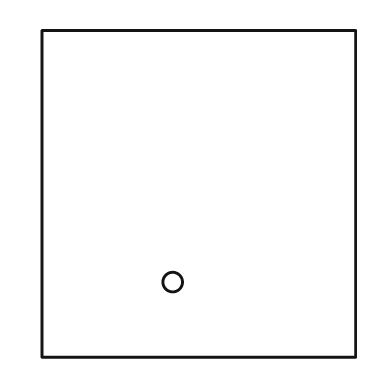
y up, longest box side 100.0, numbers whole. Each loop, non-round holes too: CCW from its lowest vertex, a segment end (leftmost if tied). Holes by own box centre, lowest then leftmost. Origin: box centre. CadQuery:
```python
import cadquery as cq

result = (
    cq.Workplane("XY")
    .moveTo(-48.0, -50.0)
    .lineTo(48.0, -50.0)
    .lineTo(48.0, 50.0)
    .lineTo(-48.0, 50.0)
    .close()
    .moveTo(-8.0, -27.0)
    .circle(3.0)
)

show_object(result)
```